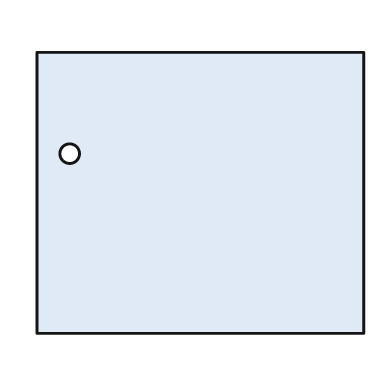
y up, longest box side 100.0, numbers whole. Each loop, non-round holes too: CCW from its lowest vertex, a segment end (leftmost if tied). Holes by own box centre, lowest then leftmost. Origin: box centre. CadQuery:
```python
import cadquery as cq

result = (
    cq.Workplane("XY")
    .moveTo(-50.0, -43.0)
    .lineTo(50.0, -43.0)
    .lineTo(50.0, 43.0)
    .lineTo(-50.0, 43.0)
    .close()
    .moveTo(-40.0, 12.0)
    .circle(3.0)
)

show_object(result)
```